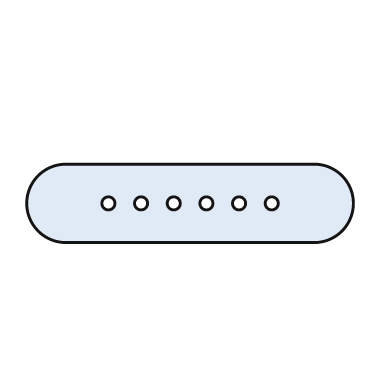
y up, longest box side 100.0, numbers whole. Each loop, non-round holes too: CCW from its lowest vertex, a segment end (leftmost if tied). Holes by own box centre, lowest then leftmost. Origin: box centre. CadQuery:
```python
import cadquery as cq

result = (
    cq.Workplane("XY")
    .moveTo(-38.0, -12.0)
    .lineTo(38.0, -12.0)
    .threePointArc((50.0, 0.0), (38.0, 12.0))
    .lineTo(-38.0, 12.0)
    .threePointArc((-50.0, 0.0), (-38.0, -12.0))
    .close()
    .moveTo(-25.0, 0.0)
    .circle(2.0)
    .moveTo(-15.0, 0.0)
    .circle(2.0)
    .moveTo(-5.0, 0.0)
    .circle(2.0)
    .moveTo(5.0, 0.0)
    .circle(2.0)
    .moveTo(15.0, 0.0)
    .circle(2.0)
    .moveTo(25.0, 0.0)
    .circle(2.0)
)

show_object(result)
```